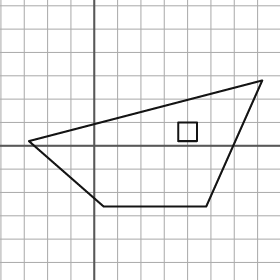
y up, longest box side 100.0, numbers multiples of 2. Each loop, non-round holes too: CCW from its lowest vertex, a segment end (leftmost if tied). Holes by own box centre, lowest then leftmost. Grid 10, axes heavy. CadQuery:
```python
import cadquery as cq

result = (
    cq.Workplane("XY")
    .moveTo(4.0, -26.0)
    .lineTo(48.0, -26.0)
    .lineTo(72.0, 28.0)
    .lineTo(-28.0, 2.0)
    .close()
    .moveTo(36.0, 2.0)
    .lineTo(44.0, 2.0)
    .lineTo(44.0, 10.0)
    .lineTo(36.0, 10.0)
    .close()
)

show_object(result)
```